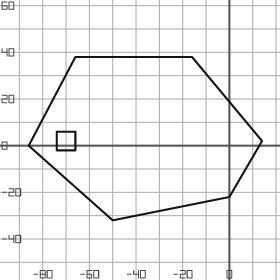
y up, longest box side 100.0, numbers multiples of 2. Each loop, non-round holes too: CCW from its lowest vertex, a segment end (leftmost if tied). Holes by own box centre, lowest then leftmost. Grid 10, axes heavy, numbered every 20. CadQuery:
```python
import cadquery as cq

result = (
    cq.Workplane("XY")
    .moveTo(-50.0, -32.0)
    .lineTo(0.0, -22.0)
    .lineTo(14.0, 2.0)
    .lineTo(-16.0, 38.0)
    .lineTo(-66.0, 38.0)
    .lineTo(-86.0, 0.0)
    .close()
    .moveTo(-74.0, -2.0)
    .lineTo(-66.0, -2.0)
    .lineTo(-66.0, 6.0)
    .lineTo(-74.0, 6.0)
    .close()
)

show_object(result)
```